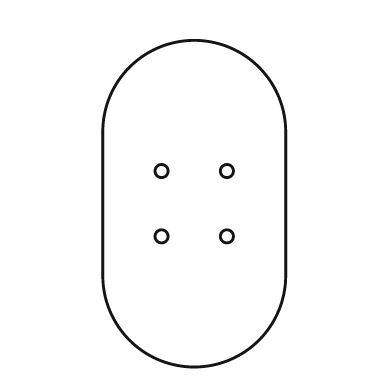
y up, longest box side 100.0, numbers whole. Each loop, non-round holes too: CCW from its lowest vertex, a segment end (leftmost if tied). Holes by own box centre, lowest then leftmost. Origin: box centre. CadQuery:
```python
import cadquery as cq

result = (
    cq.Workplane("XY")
    .moveTo(-28.0, -22.0)
    .threePointArc((0.0, -50.0), (28.0, -22.0))
    .lineTo(28.0, 22.0)
    .threePointArc((0.0, 50.0), (-28.0, 22.0))
    .close()
    .moveTo(-10.0, -10.0)
    .circle(2.0)
    .moveTo(10.0, -10.0)
    .circle(2.0)
    .moveTo(-10.0, 10.0)
    .circle(2.0)
    .moveTo(10.0, 10.0)
    .circle(2.0)
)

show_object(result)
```